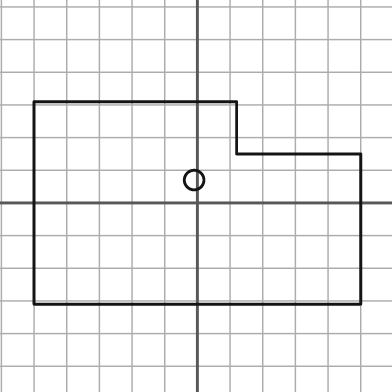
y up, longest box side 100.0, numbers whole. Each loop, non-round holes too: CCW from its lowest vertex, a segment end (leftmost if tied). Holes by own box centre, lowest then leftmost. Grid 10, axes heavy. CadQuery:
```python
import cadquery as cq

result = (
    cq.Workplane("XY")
    .moveTo(-50.0, -31.0)
    .lineTo(50.0, -31.0)
    .lineTo(50.0, 15.0)
    .lineTo(12.0, 15.0)
    .lineTo(12.0, 31.0)
    .lineTo(-50.0, 31.0)
    .close()
    .moveTo(-1.0, 7.0)
    .circle(3.0)
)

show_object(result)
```